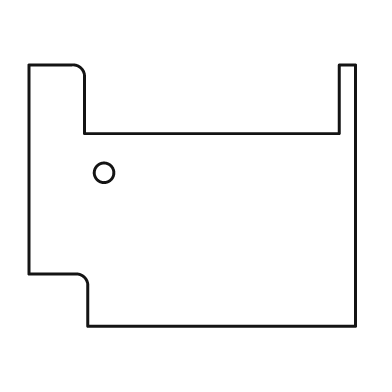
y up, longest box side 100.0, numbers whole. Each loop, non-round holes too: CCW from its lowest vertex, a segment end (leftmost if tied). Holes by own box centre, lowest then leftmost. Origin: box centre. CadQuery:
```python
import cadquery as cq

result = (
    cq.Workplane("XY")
    .moveTo(-32.0, -40.0)
    .lineTo(50.0, -40.0)
    .lineTo(50.0, 40.0)
    .lineTo(45.0, 40.0)
    .lineTo(45.0, 19.0)
    .lineTo(-33.0, 19.0)
    .lineTo(-33.0, 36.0)
    .threePointArc((-34.0, 39.0), (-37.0, 40.0))
    .lineTo(-50.0, 40.0)
    .lineTo(-50.0, -24.0)
    .lineTo(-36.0, -24.0)
    .threePointArc((-33.0, -25.0), (-32.0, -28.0))
    .close()
    .moveTo(-27.0, 7.0)
    .circle(3.0)
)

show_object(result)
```